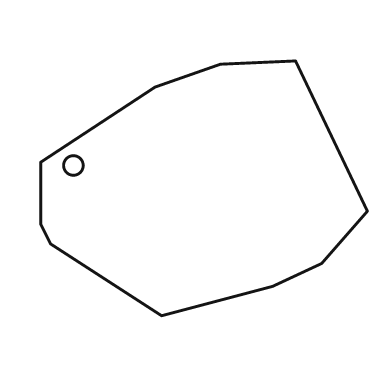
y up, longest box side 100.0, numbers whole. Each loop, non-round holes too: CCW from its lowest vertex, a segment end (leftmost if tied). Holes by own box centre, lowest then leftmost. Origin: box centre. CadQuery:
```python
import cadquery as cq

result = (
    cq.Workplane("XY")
    .moveTo(-13.0, -39.0)
    .lineTo(21.0, -30.0)
    .lineTo(36.0, -23.0)
    .lineTo(50.0, -7.0)
    .lineTo(28.0, 39.0)
    .lineTo(5.0, 38.0)
    .lineTo(-15.0, 31.0)
    .lineTo(-50.0, 8.0)
    .lineTo(-50.0, -11.0)
    .lineTo(-47.0, -17.0)
    .close()
    .moveTo(-40.0, 7.0)
    .circle(3.0)
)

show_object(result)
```